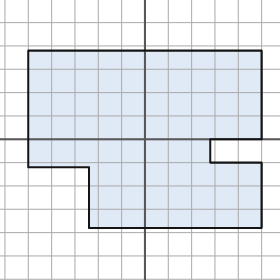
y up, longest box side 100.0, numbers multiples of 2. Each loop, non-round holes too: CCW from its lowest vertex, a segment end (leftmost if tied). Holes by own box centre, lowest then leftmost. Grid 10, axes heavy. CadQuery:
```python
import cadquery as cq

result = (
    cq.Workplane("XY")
    .moveTo(-24.0, -38.0)
    .lineTo(50.0, -38.0)
    .lineTo(50.0, -10.0)
    .lineTo(28.0, -10.0)
    .lineTo(28.0, 0.0)
    .lineTo(50.0, 0.0)
    .lineTo(50.0, 38.0)
    .lineTo(-50.0, 38.0)
    .lineTo(-50.0, -12.0)
    .lineTo(-24.0, -12.0)
    .close()
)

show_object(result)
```